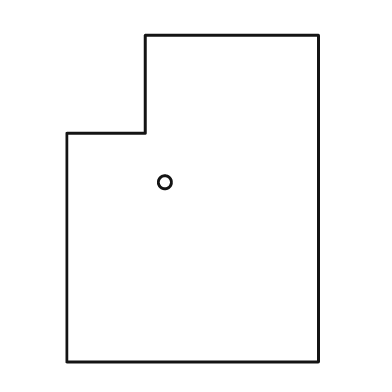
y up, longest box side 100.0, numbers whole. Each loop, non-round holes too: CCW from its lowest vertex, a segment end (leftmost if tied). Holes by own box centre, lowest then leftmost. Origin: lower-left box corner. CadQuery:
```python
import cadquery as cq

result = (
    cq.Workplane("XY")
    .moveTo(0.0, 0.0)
    .lineTo(77.0, 0.0)
    .lineTo(77.0, 100.0)
    .lineTo(24.0, 100.0)
    .lineTo(24.0, 70.0)
    .lineTo(0.0, 70.0)
    .close()
    .moveTo(30.0, 55.0)
    .circle(2.0)
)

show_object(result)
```